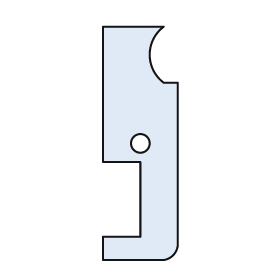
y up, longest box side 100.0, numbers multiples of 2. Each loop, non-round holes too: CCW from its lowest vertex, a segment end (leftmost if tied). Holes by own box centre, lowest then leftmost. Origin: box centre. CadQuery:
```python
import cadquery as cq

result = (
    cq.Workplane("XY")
    .moveTo(-16.0, -50.0)
    .lineTo(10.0, -50.0)
    .threePointArc((14.0, -48.0), (16.0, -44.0))
    .lineTo(16.0, 26.0)
    .lineTo(10.0, 26.0)
    .threePointArc((4.0, 38.0), (10.0, 50.0))
    .lineTo(-16.0, 50.0)
    .lineTo(-16.0, -8.0)
    .lineTo(0.0, -8.0)
    .lineTo(0.0, -40.0)
    .lineTo(-16.0, -40.0)
    .close()
    .moveTo(0.0, 0.0)
    .circle(4.0)
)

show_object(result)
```